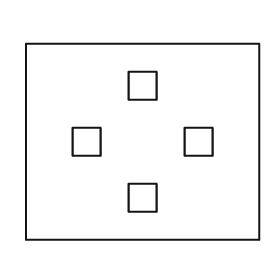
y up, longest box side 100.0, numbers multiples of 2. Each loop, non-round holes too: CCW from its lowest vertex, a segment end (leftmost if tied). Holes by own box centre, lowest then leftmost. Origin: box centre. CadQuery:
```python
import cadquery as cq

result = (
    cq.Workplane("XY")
    .moveTo(-50.0, -42.0)
    .lineTo(50.0, -42.0)
    .lineTo(50.0, 42.0)
    .lineTo(-50.0, 42.0)
    .close()
    .moveTo(-6.0, -30.0)
    .lineTo(6.0, -30.0)
    .lineTo(6.0, -18.0)
    .lineTo(-6.0, -18.0)
    .close()
    .moveTo(-30.0, -6.0)
    .lineTo(-18.0, -6.0)
    .lineTo(-18.0, 6.0)
    .lineTo(-30.0, 6.0)
    .close()
    .moveTo(18.0, -6.0)
    .lineTo(30.0, -6.0)
    .lineTo(30.0, 6.0)
    .lineTo(18.0, 6.0)
    .close()
    .moveTo(-6.0, 18.0)
    .lineTo(6.0, 18.0)
    .lineTo(6.0, 30.0)
    .lineTo(-6.0, 30.0)
    .close()
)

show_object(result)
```